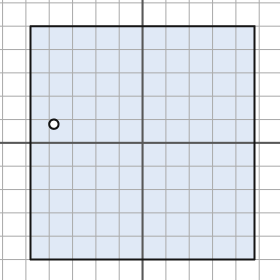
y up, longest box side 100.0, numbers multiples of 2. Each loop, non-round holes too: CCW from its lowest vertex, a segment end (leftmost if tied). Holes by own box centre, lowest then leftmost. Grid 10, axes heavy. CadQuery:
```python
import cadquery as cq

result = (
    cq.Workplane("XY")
    .moveTo(-48.0, -50.0)
    .lineTo(48.0, -50.0)
    .lineTo(48.0, 50.0)
    .lineTo(-48.0, 50.0)
    .close()
    .moveTo(-38.0, 8.0)
    .circle(2.0)
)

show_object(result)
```